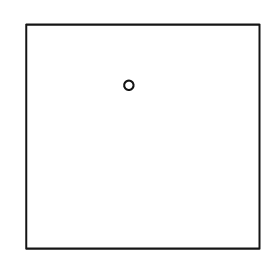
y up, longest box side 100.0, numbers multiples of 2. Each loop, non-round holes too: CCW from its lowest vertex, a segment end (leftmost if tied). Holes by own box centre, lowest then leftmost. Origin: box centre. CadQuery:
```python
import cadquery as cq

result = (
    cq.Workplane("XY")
    .moveTo(-50.0, -48.0)
    .lineTo(50.0, -48.0)
    .lineTo(50.0, 48.0)
    .lineTo(-50.0, 48.0)
    .close()
    .moveTo(-6.0, 22.0)
    .circle(2.0)
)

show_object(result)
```